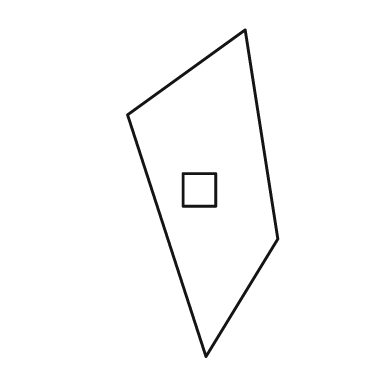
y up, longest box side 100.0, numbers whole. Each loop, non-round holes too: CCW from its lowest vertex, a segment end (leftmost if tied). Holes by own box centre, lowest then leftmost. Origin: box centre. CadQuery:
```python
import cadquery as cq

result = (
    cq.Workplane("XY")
    .moveTo(1.0, -50.0)
    .lineTo(23.0, -14.0)
    .lineTo(13.0, 50.0)
    .lineTo(-23.0, 24.0)
    .close()
    .moveTo(-6.0, -4.0)
    .lineTo(4.0, -4.0)
    .lineTo(4.0, 6.0)
    .lineTo(-6.0, 6.0)
    .close()
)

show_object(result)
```